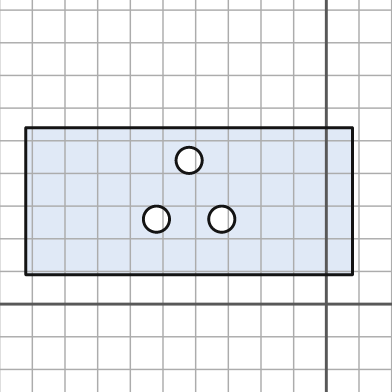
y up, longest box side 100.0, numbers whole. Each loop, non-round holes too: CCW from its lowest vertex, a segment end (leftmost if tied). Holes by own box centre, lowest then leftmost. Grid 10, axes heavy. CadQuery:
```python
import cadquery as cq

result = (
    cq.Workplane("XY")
    .moveTo(-92.0, 9.0)
    .lineTo(8.0, 9.0)
    .lineTo(8.0, 54.0)
    .lineTo(-92.0, 54.0)
    .close()
    .moveTo(-52.0, 26.0)
    .circle(4.0)
    .moveTo(-32.0, 26.0)
    .circle(4.0)
    .moveTo(-42.0, 44.0)
    .circle(4.0)
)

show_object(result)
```